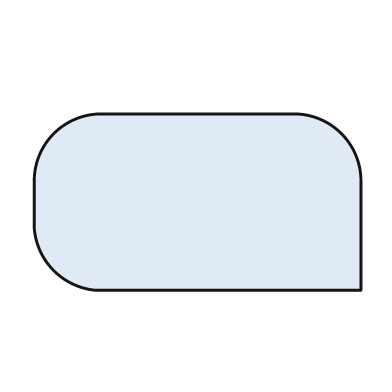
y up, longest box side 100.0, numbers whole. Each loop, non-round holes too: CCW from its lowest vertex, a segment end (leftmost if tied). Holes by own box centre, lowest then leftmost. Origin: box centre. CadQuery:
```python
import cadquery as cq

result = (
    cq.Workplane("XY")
    .moveTo(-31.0, -27.0)
    .lineTo(50.0, -27.0)
    .lineTo(50.0, 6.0)
    .threePointArc((44.0, 21.0), (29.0, 27.0))
    .lineTo(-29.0, 27.0)
    .threePointArc((-44.0, 21.0), (-50.0, 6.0))
    .lineTo(-50.0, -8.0)
    .threePointArc((-44.0, -21.0), (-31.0, -27.0))
    .close()
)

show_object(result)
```